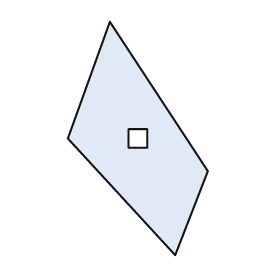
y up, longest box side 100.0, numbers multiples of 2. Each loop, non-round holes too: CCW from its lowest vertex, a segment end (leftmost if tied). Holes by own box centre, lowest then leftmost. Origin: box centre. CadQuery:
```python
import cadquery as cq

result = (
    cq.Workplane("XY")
    .moveTo(16.0, -50.0)
    .lineTo(30.0, -14.0)
    .lineTo(-12.0, 50.0)
    .lineTo(-30.0, 0.0)
    .close()
    .moveTo(-4.0, -4.0)
    .lineTo(4.0, -4.0)
    .lineTo(4.0, 4.0)
    .lineTo(-4.0, 4.0)
    .close()
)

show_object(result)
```